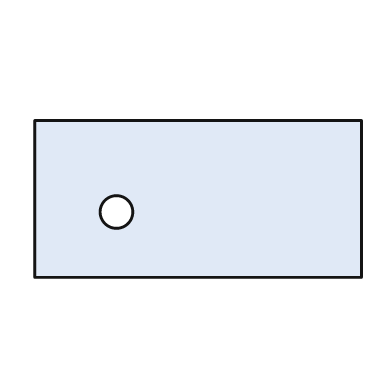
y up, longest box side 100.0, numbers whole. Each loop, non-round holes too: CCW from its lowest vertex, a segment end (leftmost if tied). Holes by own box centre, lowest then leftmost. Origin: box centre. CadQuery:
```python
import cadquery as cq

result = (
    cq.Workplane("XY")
    .moveTo(-50.0, -24.0)
    .lineTo(50.0, -24.0)
    .lineTo(50.0, 24.0)
    .lineTo(-50.0, 24.0)
    .close()
    .moveTo(-25.0, -4.0)
    .circle(5.0)
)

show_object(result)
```